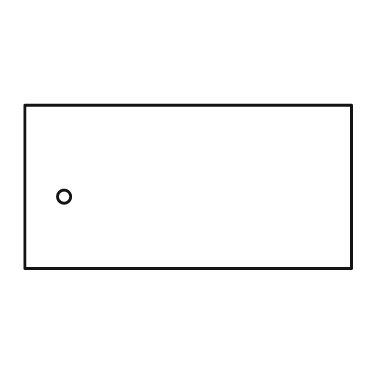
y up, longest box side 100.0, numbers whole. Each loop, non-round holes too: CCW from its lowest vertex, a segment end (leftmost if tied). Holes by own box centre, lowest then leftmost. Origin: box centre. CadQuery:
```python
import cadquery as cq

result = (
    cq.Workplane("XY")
    .moveTo(-50.0, -25.0)
    .lineTo(50.0, -25.0)
    .lineTo(50.0, 25.0)
    .lineTo(-50.0, 25.0)
    .close()
    .moveTo(-38.0, -3.0)
    .circle(2.0)
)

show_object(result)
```